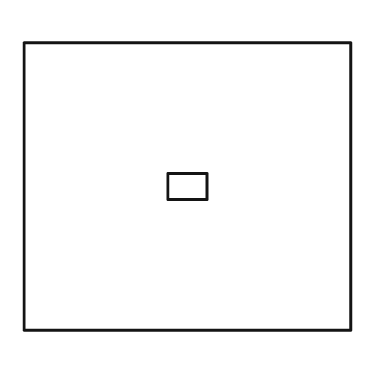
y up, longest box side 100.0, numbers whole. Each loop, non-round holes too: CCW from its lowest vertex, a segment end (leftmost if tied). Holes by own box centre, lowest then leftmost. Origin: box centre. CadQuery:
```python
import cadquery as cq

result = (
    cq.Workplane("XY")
    .moveTo(-50.0, -44.0)
    .lineTo(50.0, -44.0)
    .lineTo(50.0, 44.0)
    .lineTo(-50.0, 44.0)
    .close()
    .moveTo(-6.0, -4.0)
    .lineTo(6.0, -4.0)
    .lineTo(6.0, 4.0)
    .lineTo(-6.0, 4.0)
    .close()
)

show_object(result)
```